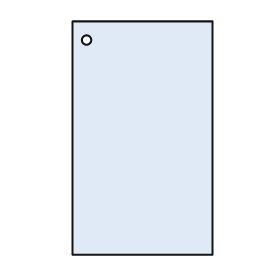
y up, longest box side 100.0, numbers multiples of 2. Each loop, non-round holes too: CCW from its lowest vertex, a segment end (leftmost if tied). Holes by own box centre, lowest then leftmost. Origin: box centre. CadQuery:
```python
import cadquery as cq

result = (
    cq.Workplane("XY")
    .moveTo(-30.0, -50.0)
    .lineTo(30.0, -50.0)
    .lineTo(30.0, 50.0)
    .lineTo(-30.0, 50.0)
    .close()
    .moveTo(-24.0, 42.0)
    .circle(2.0)
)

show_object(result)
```